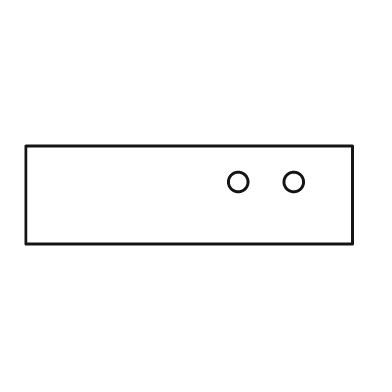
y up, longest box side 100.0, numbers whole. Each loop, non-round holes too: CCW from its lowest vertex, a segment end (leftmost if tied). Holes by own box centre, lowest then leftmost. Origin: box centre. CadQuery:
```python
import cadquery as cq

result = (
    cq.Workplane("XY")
    .moveTo(-50.0, -15.0)
    .lineTo(50.0, -15.0)
    .lineTo(50.0, 15.0)
    .lineTo(-50.0, 15.0)
    .close()
    .moveTo(15.0, 4.0)
    .circle(3.0)
    .moveTo(32.0, 4.0)
    .circle(3.0)
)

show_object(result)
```